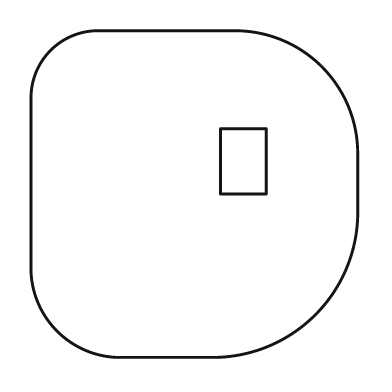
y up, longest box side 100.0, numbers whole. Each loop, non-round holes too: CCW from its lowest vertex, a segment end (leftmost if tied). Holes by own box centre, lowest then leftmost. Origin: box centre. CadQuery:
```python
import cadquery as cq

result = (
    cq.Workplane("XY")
    .moveTo(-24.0, -50.0)
    .lineTo(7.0, -50.0)
    .threePointArc((37.0, -37.0), (50.0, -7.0))
    .lineTo(50.0, 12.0)
    .threePointArc((39.0, 39.0), (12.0, 50.0))
    .lineTo(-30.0, 50.0)
    .threePointArc((-44.0, 44.0), (-50.0, 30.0))
    .lineTo(-50.0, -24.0)
    .threePointArc((-42.0, -42.0), (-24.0, -50.0))
    .close()
    .moveTo(8.0, 0.0)
    .lineTo(22.0, 0.0)
    .lineTo(22.0, 20.0)
    .lineTo(8.0, 20.0)
    .close()
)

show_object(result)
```